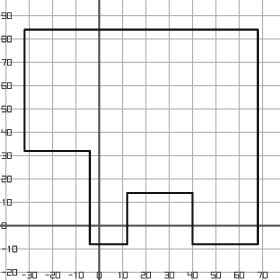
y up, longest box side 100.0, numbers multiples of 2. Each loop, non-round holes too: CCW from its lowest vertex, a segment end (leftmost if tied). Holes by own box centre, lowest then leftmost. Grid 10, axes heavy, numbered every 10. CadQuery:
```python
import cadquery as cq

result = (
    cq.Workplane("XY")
    .moveTo(-4.0, -8.0)
    .lineTo(12.0, -8.0)
    .lineTo(12.0, 14.0)
    .lineTo(40.0, 14.0)
    .lineTo(40.0, -8.0)
    .lineTo(68.0, -8.0)
    .lineTo(68.0, 84.0)
    .lineTo(-32.0, 84.0)
    .lineTo(-32.0, 32.0)
    .lineTo(-4.0, 32.0)
    .close()
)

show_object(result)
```